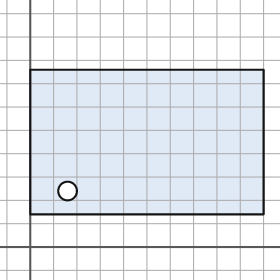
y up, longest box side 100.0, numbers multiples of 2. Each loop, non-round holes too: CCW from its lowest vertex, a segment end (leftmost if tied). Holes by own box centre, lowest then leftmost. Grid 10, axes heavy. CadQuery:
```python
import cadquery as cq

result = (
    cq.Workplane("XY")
    .moveTo(0.0, 14.0)
    .lineTo(100.0, 14.0)
    .lineTo(100.0, 76.0)
    .lineTo(0.0, 76.0)
    .close()
    .moveTo(16.0, 24.0)
    .circle(4.0)
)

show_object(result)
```